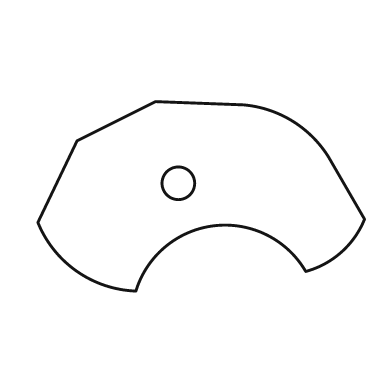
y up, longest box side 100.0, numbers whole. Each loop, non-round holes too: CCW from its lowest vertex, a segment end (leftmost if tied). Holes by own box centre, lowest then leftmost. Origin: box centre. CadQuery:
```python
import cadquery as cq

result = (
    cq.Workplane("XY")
    .moveTo(-20.0, -29.0)
    .threePointArc((4.0, -9.0), (32.0, -23.0))
    .threePointArc((43.0, -17.0), (50.0, -7.0))
    .lineTo(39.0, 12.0)
    .threePointArc((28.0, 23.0), (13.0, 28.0))
    .lineTo(-14.0, 29.0)
    .lineTo(-38.0, 17.0)
    .lineTo(-50.0, -8.0)
    .threePointArc((-38.0, -23.0), (-20.0, -29.0))
    .close()
    .moveTo(-7.0, 4.0)
    .circle(5.0)
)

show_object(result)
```